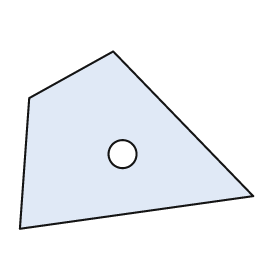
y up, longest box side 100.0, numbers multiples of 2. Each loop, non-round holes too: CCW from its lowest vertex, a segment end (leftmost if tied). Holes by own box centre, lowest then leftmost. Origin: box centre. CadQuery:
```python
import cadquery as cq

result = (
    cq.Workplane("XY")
    .moveTo(-50.0, -38.0)
    .lineTo(50.0, -24.0)
    .lineTo(-10.0, 38.0)
    .lineTo(-46.0, 18.0)
    .close()
    .moveTo(-6.0, -6.0)
    .circle(6.0)
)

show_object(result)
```